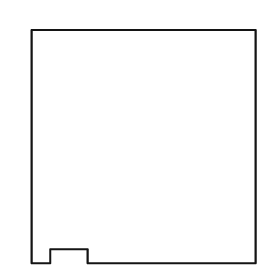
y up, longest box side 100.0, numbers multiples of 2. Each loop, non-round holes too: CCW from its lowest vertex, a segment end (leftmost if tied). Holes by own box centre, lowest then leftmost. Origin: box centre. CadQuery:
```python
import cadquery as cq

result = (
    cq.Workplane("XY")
    .moveTo(-48.0, -50.0)
    .lineTo(-40.0, -50.0)
    .lineTo(-40.0, -44.0)
    .lineTo(-24.0, -44.0)
    .lineTo(-24.0, -50.0)
    .lineTo(48.0, -50.0)
    .lineTo(48.0, 50.0)
    .lineTo(-48.0, 50.0)
    .close()
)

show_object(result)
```